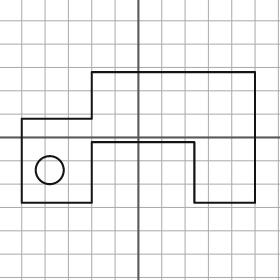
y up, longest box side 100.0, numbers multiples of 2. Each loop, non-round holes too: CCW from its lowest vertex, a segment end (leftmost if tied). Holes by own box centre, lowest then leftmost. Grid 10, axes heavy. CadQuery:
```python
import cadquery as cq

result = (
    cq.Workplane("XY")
    .moveTo(-50.0, -28.0)
    .lineTo(-20.0, -28.0)
    .lineTo(-20.0, -2.0)
    .lineTo(24.0, -2.0)
    .lineTo(24.0, -28.0)
    .lineTo(50.0, -28.0)
    .lineTo(50.0, 28.0)
    .lineTo(-20.0, 28.0)
    .lineTo(-20.0, 8.0)
    .lineTo(-50.0, 8.0)
    .close()
    .moveTo(-38.0, -14.0)
    .circle(6.0)
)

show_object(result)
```